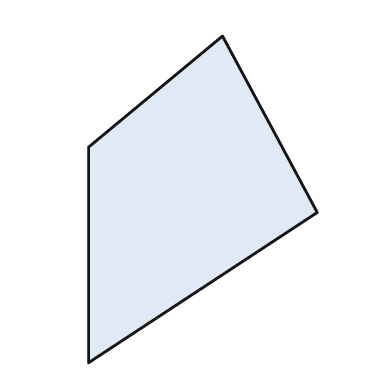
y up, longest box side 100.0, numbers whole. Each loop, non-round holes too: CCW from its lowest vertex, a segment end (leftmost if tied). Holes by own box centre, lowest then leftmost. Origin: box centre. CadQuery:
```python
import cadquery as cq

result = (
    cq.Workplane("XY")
    .moveTo(-35.0, -50.0)
    .lineTo(35.0, -4.0)
    .lineTo(6.0, 50.0)
    .lineTo(-35.0, 16.0)
    .close()
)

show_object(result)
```